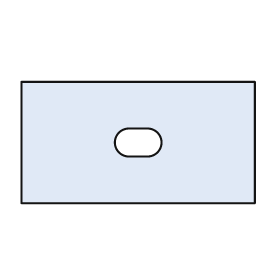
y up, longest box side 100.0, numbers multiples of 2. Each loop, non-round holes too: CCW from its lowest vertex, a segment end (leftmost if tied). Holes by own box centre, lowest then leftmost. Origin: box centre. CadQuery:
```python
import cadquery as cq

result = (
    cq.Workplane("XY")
    .moveTo(-50.0, -26.0)
    .lineTo(50.0, -26.0)
    .lineTo(50.0, 26.0)
    .lineTo(-50.0, 26.0)
    .close()
    .moveTo(-4.0, -6.0)
    .lineTo(4.0, -6.0)
    .threePointArc((10.0, 0.0), (4.0, 6.0))
    .lineTo(-4.0, 6.0)
    .threePointArc((-10.0, 0.0), (-4.0, -6.0))
    .close()
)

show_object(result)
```